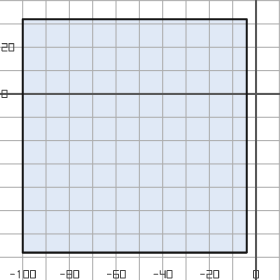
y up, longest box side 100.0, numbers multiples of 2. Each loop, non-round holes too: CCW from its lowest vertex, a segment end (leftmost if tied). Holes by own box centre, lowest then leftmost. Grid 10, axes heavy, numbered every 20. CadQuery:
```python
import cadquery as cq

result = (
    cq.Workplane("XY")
    .moveTo(-100.0, -68.0)
    .lineTo(-4.0, -68.0)
    .lineTo(-4.0, 32.0)
    .lineTo(-100.0, 32.0)
    .close()
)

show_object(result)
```